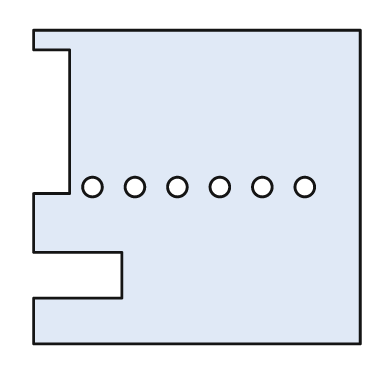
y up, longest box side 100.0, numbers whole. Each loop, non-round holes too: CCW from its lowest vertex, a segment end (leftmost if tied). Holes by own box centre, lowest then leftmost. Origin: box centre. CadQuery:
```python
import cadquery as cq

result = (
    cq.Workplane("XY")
    .moveTo(-50.0, -48.0)
    .lineTo(50.0, -48.0)
    .lineTo(50.0, 48.0)
    .lineTo(-50.0, 48.0)
    .lineTo(-50.0, 42.0)
    .lineTo(-39.0, 42.0)
    .lineTo(-39.0, -2.0)
    .lineTo(-50.0, -2.0)
    .lineTo(-50.0, -20.0)
    .lineTo(-23.0, -20.0)
    .lineTo(-23.0, -34.0)
    .lineTo(-50.0, -34.0)
    .close()
    .moveTo(-32.0, 0.0)
    .circle(3.0)
    .moveTo(-19.0, 0.0)
    .circle(3.0)
    .moveTo(-6.0, 0.0)
    .circle(3.0)
    .moveTo(7.0, 0.0)
    .circle(3.0)
    .moveTo(20.0, 0.0)
    .circle(3.0)
    .moveTo(33.0, 0.0)
    .circle(3.0)
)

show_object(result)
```